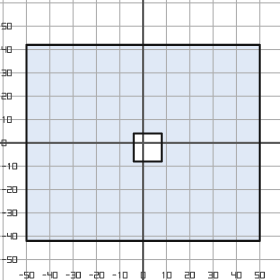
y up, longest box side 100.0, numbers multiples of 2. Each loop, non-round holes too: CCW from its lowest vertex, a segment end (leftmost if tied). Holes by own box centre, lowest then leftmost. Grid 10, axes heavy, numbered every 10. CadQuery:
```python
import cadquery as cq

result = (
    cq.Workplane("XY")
    .moveTo(-50.0, -42.0)
    .lineTo(50.0, -42.0)
    .lineTo(50.0, 42.0)
    .lineTo(-50.0, 42.0)
    .close()
    .moveTo(-4.0, -8.0)
    .lineTo(8.0, -8.0)
    .lineTo(8.0, 4.0)
    .lineTo(-4.0, 4.0)
    .close()
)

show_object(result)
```